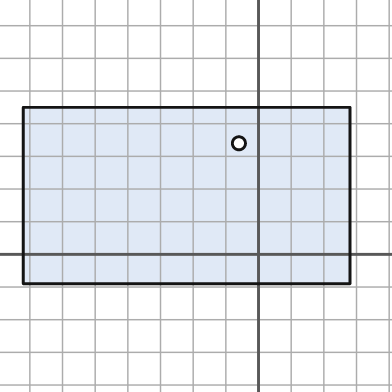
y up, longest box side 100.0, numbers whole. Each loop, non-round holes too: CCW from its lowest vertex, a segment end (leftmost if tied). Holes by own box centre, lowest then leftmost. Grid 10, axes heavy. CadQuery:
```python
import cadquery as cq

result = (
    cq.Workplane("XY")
    .moveTo(-72.0, -9.0)
    .lineTo(28.0, -9.0)
    .lineTo(28.0, 45.0)
    .lineTo(-72.0, 45.0)
    .close()
    .moveTo(-6.0, 34.0)
    .circle(2.0)
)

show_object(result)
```